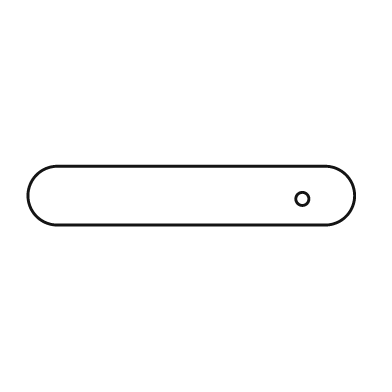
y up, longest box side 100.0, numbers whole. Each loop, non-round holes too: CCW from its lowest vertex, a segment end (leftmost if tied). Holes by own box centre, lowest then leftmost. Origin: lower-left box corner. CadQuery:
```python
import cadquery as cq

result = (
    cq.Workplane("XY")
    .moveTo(9.0, 0.0)
    .lineTo(91.0, 0.0)
    .threePointArc((100.0, 9.0), (91.0, 18.0))
    .lineTo(9.0, 18.0)
    .threePointArc((0.0, 9.0), (9.0, 0.0))
    .close()
    .moveTo(84.0, 8.0)
    .circle(2.0)
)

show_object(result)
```